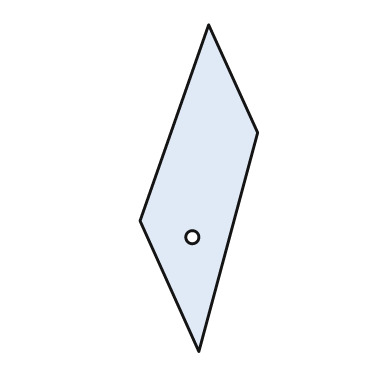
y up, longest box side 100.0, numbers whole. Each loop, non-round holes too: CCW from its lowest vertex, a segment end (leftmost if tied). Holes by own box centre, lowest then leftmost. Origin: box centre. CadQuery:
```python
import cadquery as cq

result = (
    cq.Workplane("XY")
    .moveTo(0.0, -50.0)
    .lineTo(18.0, 17.0)
    .lineTo(3.0, 50.0)
    .lineTo(-18.0, -10.0)
    .close()
    .moveTo(-2.0, -15.0)
    .circle(2.0)
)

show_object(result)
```